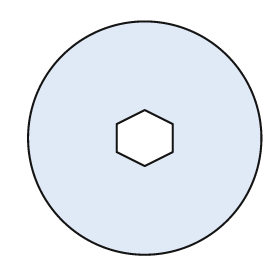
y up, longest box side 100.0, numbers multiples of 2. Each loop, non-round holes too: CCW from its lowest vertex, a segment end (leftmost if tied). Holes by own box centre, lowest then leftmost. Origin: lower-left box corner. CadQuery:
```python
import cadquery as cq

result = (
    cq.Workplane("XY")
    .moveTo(50.0, 50.0)
    .circle(50.0)
    .moveTo(50.0, 38.0)
    .lineTo(62.0, 44.0)
    .lineTo(62.0, 56.0)
    .lineTo(50.0, 62.0)
    .lineTo(38.0, 56.0)
    .lineTo(38.0, 44.0)
    .close()
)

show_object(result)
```